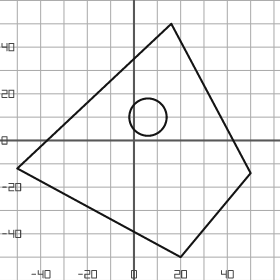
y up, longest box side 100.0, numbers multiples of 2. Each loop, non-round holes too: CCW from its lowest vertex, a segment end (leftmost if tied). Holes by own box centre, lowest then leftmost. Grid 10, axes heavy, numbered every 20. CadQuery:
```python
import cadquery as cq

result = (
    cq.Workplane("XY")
    .moveTo(20.0, -50.0)
    .lineTo(50.0, -14.0)
    .lineTo(16.0, 50.0)
    .lineTo(-50.0, -12.0)
    .close()
    .moveTo(6.0, 10.0)
    .circle(8.0)
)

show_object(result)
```